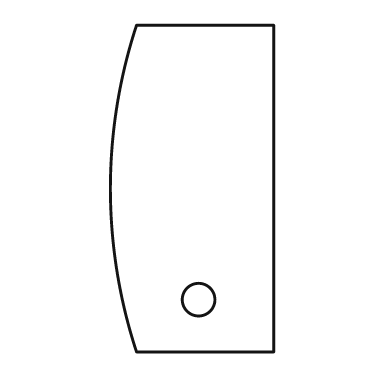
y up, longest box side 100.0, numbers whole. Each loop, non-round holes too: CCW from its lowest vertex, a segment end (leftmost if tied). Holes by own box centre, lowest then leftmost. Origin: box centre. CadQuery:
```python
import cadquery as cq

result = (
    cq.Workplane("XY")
    .moveTo(-17.0, -50.0)
    .lineTo(25.0, -50.0)
    .lineTo(25.0, 50.0)
    .lineTo(-17.0, 50.0)
    .threePointArc((-25.0, 0.0), (-17.0, -50.0))
    .close()
    .moveTo(2.0, -34.0)
    .circle(5.0)
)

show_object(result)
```